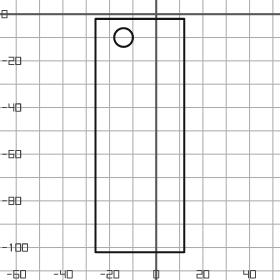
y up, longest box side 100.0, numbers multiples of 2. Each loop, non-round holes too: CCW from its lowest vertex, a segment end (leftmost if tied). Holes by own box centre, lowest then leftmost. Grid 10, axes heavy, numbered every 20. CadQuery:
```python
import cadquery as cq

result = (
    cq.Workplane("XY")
    .moveTo(-26.0, -102.0)
    .lineTo(12.0, -102.0)
    .lineTo(12.0, -2.0)
    .lineTo(-26.0, -2.0)
    .close()
    .moveTo(-14.0, -10.0)
    .circle(4.0)
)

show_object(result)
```